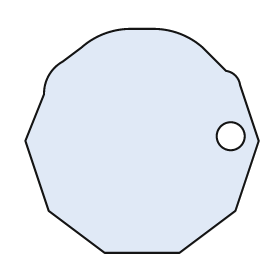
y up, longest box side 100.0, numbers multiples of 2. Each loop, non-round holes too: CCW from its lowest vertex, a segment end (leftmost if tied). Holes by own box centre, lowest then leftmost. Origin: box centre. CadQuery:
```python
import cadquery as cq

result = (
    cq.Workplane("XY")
    .moveTo(-16.0, -48.0)
    .lineTo(16.0, -48.0)
    .lineTo(40.0, -30.0)
    .lineTo(50.0, 0.0)
    .lineTo(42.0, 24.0)
    .threePointArc((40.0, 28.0), (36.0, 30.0))
    .lineTo(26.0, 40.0)
    .threePointArc((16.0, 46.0), (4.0, 48.0))
    .lineTo(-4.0, 48.0)
    .threePointArc((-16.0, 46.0), (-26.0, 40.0))
    .lineTo(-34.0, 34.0)
    .threePointArc((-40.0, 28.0), (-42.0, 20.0))
    .lineTo(-50.0, 0.0)
    .lineTo(-40.0, -30.0)
    .close()
    .moveTo(38.0, 2.0)
    .circle(6.0)
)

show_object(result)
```